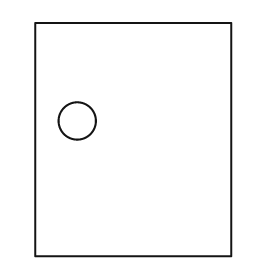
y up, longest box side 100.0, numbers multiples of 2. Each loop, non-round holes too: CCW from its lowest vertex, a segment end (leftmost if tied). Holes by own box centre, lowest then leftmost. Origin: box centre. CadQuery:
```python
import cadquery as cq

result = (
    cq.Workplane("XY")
    .moveTo(-42.0, -50.0)
    .lineTo(42.0, -50.0)
    .lineTo(42.0, 50.0)
    .lineTo(-42.0, 50.0)
    .close()
    .moveTo(-24.0, 8.0)
    .circle(8.0)
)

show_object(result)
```